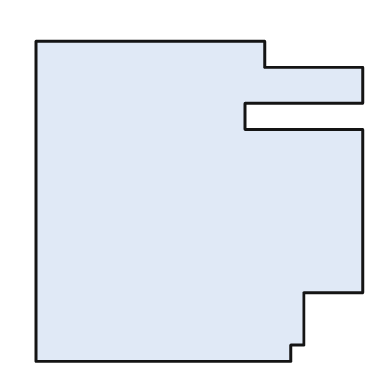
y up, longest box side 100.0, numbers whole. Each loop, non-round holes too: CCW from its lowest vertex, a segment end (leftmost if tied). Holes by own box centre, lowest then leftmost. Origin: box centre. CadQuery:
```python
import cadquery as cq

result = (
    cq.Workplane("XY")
    .moveTo(-50.0, -49.0)
    .lineTo(28.0, -49.0)
    .lineTo(28.0, -44.0)
    .lineTo(32.0, -44.0)
    .lineTo(32.0, -28.0)
    .lineTo(50.0, -28.0)
    .lineTo(50.0, 22.0)
    .lineTo(14.0, 22.0)
    .lineTo(14.0, 30.0)
    .lineTo(50.0, 30.0)
    .lineTo(50.0, 41.0)
    .lineTo(20.0, 41.0)
    .lineTo(20.0, 49.0)
    .lineTo(-50.0, 49.0)
    .close()
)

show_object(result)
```